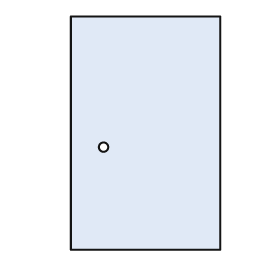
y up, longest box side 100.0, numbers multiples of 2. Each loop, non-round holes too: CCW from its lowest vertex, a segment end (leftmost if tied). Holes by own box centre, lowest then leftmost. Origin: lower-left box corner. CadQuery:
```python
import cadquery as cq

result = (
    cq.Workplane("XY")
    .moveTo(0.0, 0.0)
    .lineTo(64.0, 0.0)
    .lineTo(64.0, 100.0)
    .lineTo(0.0, 100.0)
    .close()
    .moveTo(14.0, 44.0)
    .circle(2.0)
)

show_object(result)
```